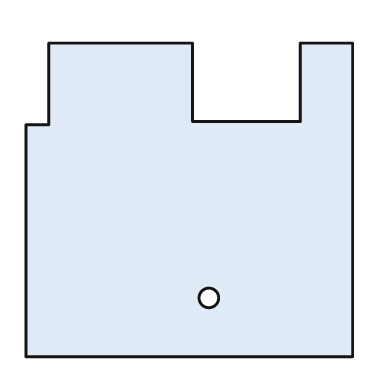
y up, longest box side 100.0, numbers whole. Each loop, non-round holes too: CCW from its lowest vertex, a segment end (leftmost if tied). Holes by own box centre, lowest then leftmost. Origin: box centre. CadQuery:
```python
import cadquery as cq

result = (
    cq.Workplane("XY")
    .moveTo(-50.0, -48.0)
    .lineTo(50.0, -48.0)
    .lineTo(50.0, 48.0)
    .lineTo(34.0, 48.0)
    .lineTo(34.0, 24.0)
    .lineTo(1.0, 24.0)
    .lineTo(1.0, 48.0)
    .lineTo(-43.0, 48.0)
    .lineTo(-43.0, 23.0)
    .lineTo(-50.0, 23.0)
    .close()
    .moveTo(6.0, -30.0)
    .circle(3.0)
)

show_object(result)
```